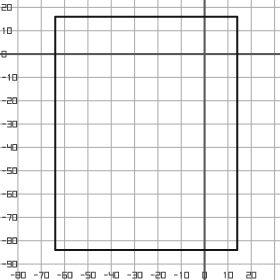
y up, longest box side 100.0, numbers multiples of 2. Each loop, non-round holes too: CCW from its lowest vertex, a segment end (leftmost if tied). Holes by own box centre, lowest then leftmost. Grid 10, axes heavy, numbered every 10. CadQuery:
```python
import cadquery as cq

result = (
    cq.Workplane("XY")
    .moveTo(-64.0, -84.0)
    .lineTo(14.0, -84.0)
    .lineTo(14.0, 16.0)
    .lineTo(-64.0, 16.0)
    .close()
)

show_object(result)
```